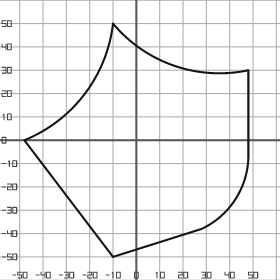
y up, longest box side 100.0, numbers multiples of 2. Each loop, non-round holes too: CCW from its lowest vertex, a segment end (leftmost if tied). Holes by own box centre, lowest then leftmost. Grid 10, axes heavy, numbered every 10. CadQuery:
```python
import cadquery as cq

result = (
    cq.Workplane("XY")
    .moveTo(-10.0, -50.0)
    .lineTo(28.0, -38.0)
    .threePointArc((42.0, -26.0), (48.0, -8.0))
    .lineTo(48.0, 30.0)
    .threePointArc((16.0, 32.0), (-10.0, 50.0))
    .threePointArc((-22.0, 20.0), (-48.0, 0.0))
    .close()
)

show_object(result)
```